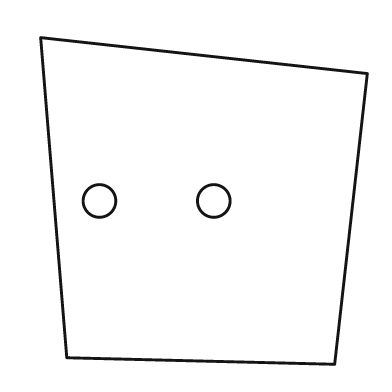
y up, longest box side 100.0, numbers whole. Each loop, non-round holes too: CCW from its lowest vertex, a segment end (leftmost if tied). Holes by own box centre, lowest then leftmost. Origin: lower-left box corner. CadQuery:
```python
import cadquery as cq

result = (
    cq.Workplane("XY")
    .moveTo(90.0, 0.0)
    .lineTo(100.0, 89.0)
    .lineTo(0.0, 100.0)
    .lineTo(8.0, 2.0)
    .close()
    .moveTo(18.0, 50.0)
    .circle(5.0)
    .moveTo(53.0, 50.0)
    .circle(5.0)
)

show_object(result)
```